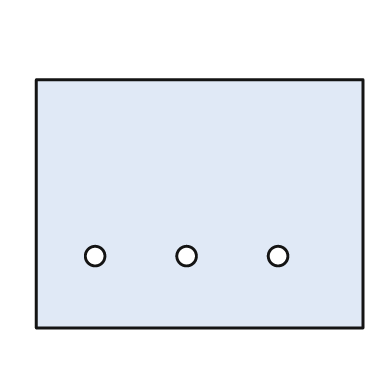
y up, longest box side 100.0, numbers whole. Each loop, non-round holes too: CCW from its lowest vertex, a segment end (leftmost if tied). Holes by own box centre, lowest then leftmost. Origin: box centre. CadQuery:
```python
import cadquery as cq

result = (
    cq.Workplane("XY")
    .moveTo(-50.0, -38.0)
    .lineTo(50.0, -38.0)
    .lineTo(50.0, 38.0)
    .lineTo(-50.0, 38.0)
    .close()
    .moveTo(-32.0, -16.0)
    .circle(3.0)
    .moveTo(-4.0, -16.0)
    .circle(3.0)
    .moveTo(24.0, -16.0)
    .circle(3.0)
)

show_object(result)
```